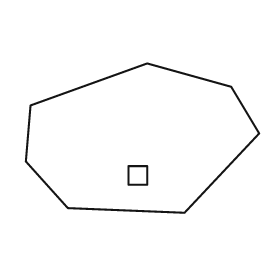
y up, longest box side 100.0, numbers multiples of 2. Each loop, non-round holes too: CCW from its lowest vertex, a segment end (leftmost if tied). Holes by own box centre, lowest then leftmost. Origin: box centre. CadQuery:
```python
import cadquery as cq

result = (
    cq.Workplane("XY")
    .moveTo(18.0, -32.0)
    .lineTo(50.0, 2.0)
    .lineTo(38.0, 22.0)
    .lineTo(2.0, 32.0)
    .lineTo(-48.0, 14.0)
    .lineTo(-50.0, -10.0)
    .lineTo(-32.0, -30.0)
    .close()
    .moveTo(-6.0, -20.0)
    .lineTo(2.0, -20.0)
    .lineTo(2.0, -12.0)
    .lineTo(-6.0, -12.0)
    .close()
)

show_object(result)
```